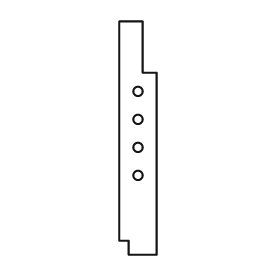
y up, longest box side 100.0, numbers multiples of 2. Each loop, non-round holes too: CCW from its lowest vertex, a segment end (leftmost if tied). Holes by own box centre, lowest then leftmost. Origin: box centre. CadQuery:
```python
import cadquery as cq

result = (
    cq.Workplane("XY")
    .moveTo(-4.0, -50.0)
    .lineTo(8.0, -50.0)
    .lineTo(8.0, 28.0)
    .lineTo(2.0, 28.0)
    .lineTo(2.0, 50.0)
    .lineTo(-8.0, 50.0)
    .lineTo(-8.0, -44.0)
    .lineTo(-4.0, -44.0)
    .close()
    .moveTo(0.0, -16.0)
    .circle(2.0)
    .moveTo(0.0, -4.0)
    .circle(2.0)
    .moveTo(0.0, 8.0)
    .circle(2.0)
    .moveTo(0.0, 20.0)
    .circle(2.0)
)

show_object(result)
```